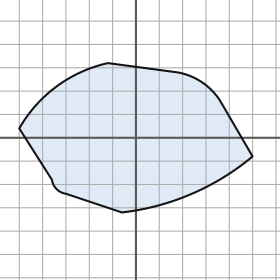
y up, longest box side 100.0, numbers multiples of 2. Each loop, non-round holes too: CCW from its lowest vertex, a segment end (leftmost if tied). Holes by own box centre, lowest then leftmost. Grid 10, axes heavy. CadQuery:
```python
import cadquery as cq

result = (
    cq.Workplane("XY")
    .moveTo(-6.0, -32.0)
    .threePointArc((24.0, -24.0), (50.0, -8.0))
    .lineTo(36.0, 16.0)
    .threePointArc((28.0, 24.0), (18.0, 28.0))
    .lineTo(-12.0, 32.0)
    .threePointArc((-34.0, 22.0), (-50.0, 4.0))
    .lineTo(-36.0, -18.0)
    .threePointArc((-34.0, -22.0), (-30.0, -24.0))
    .close()
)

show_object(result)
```